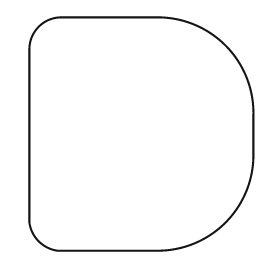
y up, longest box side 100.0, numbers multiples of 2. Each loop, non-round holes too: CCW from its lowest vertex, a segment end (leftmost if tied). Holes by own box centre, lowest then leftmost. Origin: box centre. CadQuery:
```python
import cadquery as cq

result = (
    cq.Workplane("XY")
    .moveTo(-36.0, -50.0)
    .lineTo(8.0, -50.0)
    .threePointArc((36.0, -38.0), (48.0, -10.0))
    .lineTo(48.0, 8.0)
    .threePointArc((36.0, 38.0), (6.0, 50.0))
    .lineTo(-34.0, 50.0)
    .threePointArc((-44.0, 46.0), (-48.0, 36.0))
    .lineTo(-48.0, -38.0)
    .threePointArc((-44.0, -46.0), (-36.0, -50.0))
    .close()
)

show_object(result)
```